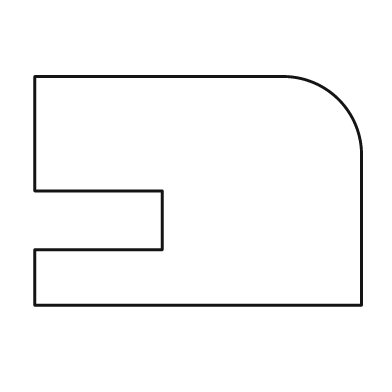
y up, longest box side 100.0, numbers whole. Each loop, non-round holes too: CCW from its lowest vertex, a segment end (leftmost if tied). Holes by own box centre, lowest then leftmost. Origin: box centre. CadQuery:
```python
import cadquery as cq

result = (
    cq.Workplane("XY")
    .moveTo(-50.0, -35.0)
    .lineTo(50.0, -35.0)
    .lineTo(50.0, 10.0)
    .threePointArc((43.0, 28.0), (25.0, 35.0))
    .lineTo(-50.0, 35.0)
    .lineTo(-50.0, 0.0)
    .lineTo(-11.0, 0.0)
    .lineTo(-11.0, -18.0)
    .lineTo(-50.0, -18.0)
    .close()
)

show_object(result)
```